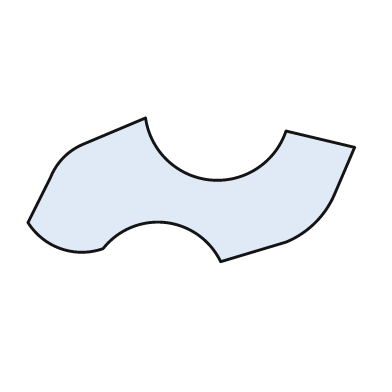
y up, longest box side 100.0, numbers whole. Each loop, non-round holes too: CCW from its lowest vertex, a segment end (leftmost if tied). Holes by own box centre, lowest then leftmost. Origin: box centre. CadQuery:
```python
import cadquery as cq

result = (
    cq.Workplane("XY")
    .moveTo(9.0, -22.0)
    .lineTo(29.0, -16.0)
    .threePointArc((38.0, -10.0), (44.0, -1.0))
    .lineTo(50.0, 13.0)
    .lineTo(29.0, 18.0)
    .threePointArc((6.0, 3.0), (-14.0, 22.0))
    .lineTo(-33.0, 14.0)
    .threePointArc((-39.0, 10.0), (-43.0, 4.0))
    .lineTo(-50.0, -10.0)
    .threePointArc((-40.0, -18.0), (-27.0, -18.0))
    .threePointArc((-8.0, -10.0), (9.0, -22.0))
    .close()
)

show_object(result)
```